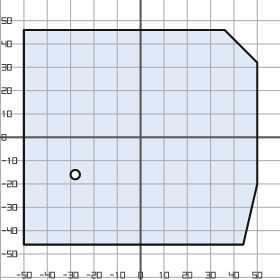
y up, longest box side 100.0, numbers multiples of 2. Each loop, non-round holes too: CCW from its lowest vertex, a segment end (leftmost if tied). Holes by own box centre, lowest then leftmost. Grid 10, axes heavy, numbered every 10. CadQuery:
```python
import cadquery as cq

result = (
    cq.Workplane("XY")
    .moveTo(-50.0, -46.0)
    .lineTo(44.0, -46.0)
    .lineTo(50.0, -20.0)
    .lineTo(50.0, 32.0)
    .lineTo(36.0, 46.0)
    .lineTo(-50.0, 46.0)
    .close()
    .moveTo(-28.0, -16.0)
    .circle(2.0)
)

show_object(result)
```